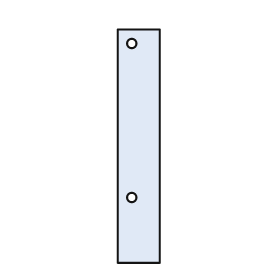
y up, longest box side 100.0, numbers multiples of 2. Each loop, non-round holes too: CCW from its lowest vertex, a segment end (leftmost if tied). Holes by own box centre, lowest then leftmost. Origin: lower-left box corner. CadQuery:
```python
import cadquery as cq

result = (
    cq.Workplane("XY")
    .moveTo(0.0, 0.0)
    .lineTo(18.0, 0.0)
    .lineTo(18.0, 100.0)
    .lineTo(0.0, 100.0)
    .close()
    .moveTo(6.0, 28.0)
    .circle(2.0)
    .moveTo(6.0, 94.0)
    .circle(2.0)
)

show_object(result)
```